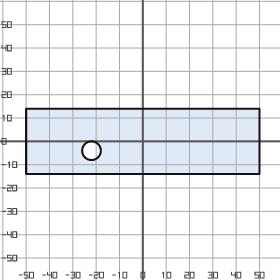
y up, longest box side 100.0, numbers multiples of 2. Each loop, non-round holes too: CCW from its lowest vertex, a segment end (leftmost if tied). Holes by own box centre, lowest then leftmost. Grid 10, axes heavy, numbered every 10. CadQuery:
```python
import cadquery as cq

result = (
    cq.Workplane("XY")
    .moveTo(-50.0, -14.0)
    .lineTo(50.0, -14.0)
    .lineTo(50.0, 14.0)
    .lineTo(-50.0, 14.0)
    .close()
    .moveTo(-22.0, -4.0)
    .circle(4.0)
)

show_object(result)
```